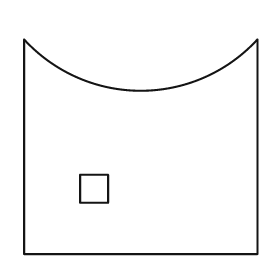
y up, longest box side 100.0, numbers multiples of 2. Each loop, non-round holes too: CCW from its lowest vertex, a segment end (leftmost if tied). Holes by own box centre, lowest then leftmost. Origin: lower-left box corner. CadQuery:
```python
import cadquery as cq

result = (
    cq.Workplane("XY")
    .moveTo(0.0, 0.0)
    .lineTo(100.0, 0.0)
    .lineTo(100.0, 92.0)
    .threePointArc((50.0, 70.0), (0.0, 92.0))
    .close()
    .moveTo(24.0, 22.0)
    .lineTo(36.0, 22.0)
    .lineTo(36.0, 34.0)
    .lineTo(24.0, 34.0)
    .close()
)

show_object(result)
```